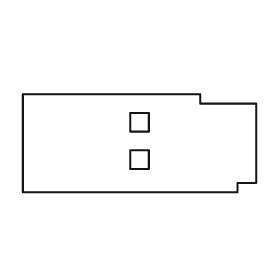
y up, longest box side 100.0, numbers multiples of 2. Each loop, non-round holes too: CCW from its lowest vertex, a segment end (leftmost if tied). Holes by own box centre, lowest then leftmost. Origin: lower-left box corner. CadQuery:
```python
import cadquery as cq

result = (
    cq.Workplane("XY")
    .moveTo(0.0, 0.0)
    .lineTo(92.0, 0.0)
    .lineTo(92.0, 4.0)
    .lineTo(100.0, 4.0)
    .lineTo(100.0, 38.0)
    .lineTo(76.0, 38.0)
    .lineTo(76.0, 42.0)
    .lineTo(0.0, 42.0)
    .close()
    .moveTo(46.0, 10.0)
    .lineTo(54.0, 10.0)
    .lineTo(54.0, 18.0)
    .lineTo(46.0, 18.0)
    .close()
    .moveTo(46.0, 26.0)
    .lineTo(54.0, 26.0)
    .lineTo(54.0, 34.0)
    .lineTo(46.0, 34.0)
    .close()
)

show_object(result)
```